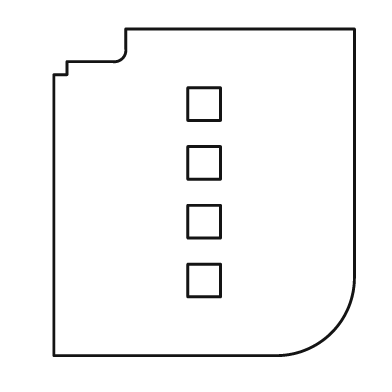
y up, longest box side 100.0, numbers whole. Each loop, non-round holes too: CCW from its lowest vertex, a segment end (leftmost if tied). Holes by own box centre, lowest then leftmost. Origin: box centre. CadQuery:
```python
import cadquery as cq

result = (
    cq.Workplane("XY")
    .moveTo(-46.0, -50.0)
    .lineTo(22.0, -50.0)
    .threePointArc((39.0, -43.0), (46.0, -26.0))
    .lineTo(46.0, 50.0)
    .lineTo(-24.0, 50.0)
    .lineTo(-24.0, 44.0)
    .threePointArc((-25.0, 41.0), (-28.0, 40.0))
    .lineTo(-42.0, 40.0)
    .lineTo(-42.0, 36.0)
    .lineTo(-46.0, 36.0)
    .close()
    .moveTo(-5.0, -32.0)
    .lineTo(5.0, -32.0)
    .lineTo(5.0, -22.0)
    .lineTo(-5.0, -22.0)
    .close()
    .moveTo(-5.0, -14.0)
    .lineTo(5.0, -14.0)
    .lineTo(5.0, -4.0)
    .lineTo(-5.0, -4.0)
    .close()
    .moveTo(-5.0, 4.0)
    .lineTo(5.0, 4.0)
    .lineTo(5.0, 14.0)
    .lineTo(-5.0, 14.0)
    .close()
    .moveTo(-5.0, 22.0)
    .lineTo(5.0, 22.0)
    .lineTo(5.0, 32.0)
    .lineTo(-5.0, 32.0)
    .close()
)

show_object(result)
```